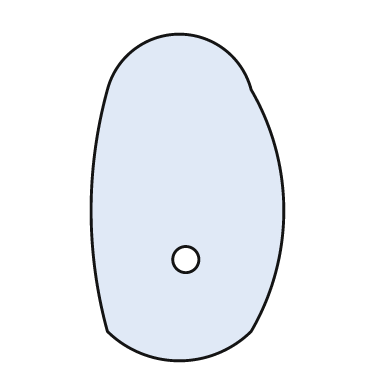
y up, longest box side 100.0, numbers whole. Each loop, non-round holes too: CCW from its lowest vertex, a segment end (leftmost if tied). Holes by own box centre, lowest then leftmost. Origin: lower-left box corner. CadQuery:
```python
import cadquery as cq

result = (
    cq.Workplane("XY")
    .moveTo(5.0, 9.0)
    .threePointArc((27.0, 0.0), (49.0, 9.0))
    .threePointArc((59.0, 46.0), (49.0, 83.0))
    .threePointArc((27.0, 100.0), (5.0, 83.0))
    .threePointArc((0.0, 46.0), (5.0, 9.0))
    .close()
    .moveTo(29.0, 31.0)
    .circle(4.0)
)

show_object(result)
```